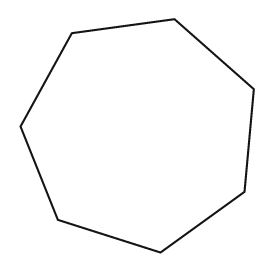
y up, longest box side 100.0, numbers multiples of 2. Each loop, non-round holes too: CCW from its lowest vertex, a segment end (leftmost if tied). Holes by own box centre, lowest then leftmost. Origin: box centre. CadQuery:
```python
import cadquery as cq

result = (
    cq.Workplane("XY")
    .moveTo(10.0, -50.0)
    .lineTo(46.0, -24.0)
    .lineTo(50.0, 20.0)
    .lineTo(16.0, 50.0)
    .lineTo(-28.0, 44.0)
    .lineTo(-50.0, 4.0)
    .lineTo(-34.0, -36.0)
    .close()
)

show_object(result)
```